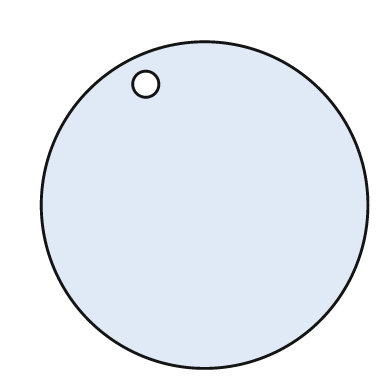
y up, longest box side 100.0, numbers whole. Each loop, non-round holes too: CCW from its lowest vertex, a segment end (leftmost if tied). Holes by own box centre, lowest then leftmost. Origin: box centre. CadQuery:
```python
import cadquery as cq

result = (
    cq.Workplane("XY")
    .moveTo(0.0, 0.0)
    .circle(50.0)
    .moveTo(-18.0, 37.0)
    .circle(4.0)
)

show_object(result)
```